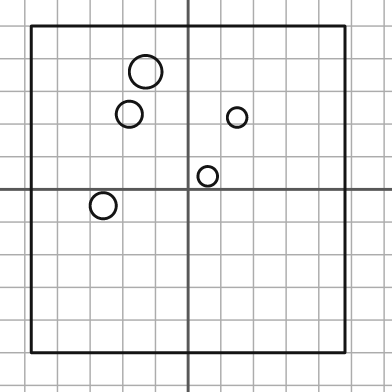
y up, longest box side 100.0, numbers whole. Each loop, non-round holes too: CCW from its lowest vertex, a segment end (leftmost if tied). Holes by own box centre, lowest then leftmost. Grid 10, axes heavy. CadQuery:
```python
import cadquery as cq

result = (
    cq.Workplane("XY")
    .moveTo(-48.0, -50.0)
    .lineTo(48.0, -50.0)
    .lineTo(48.0, 50.0)
    .lineTo(-48.0, 50.0)
    .close()
    .moveTo(-26.0, -5.0)
    .circle(4.0)
    .moveTo(6.0, 4.0)
    .circle(3.0)
    .moveTo(15.0, 22.0)
    .circle(3.0)
    .moveTo(-18.0, 23.0)
    .circle(4.0)
    .moveTo(-13.0, 36.0)
    .circle(5.0)
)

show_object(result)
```